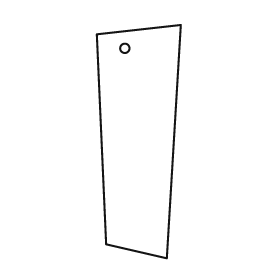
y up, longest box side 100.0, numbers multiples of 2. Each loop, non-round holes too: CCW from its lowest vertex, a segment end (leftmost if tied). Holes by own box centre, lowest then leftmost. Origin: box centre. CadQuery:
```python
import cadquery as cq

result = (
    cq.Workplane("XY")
    .moveTo(12.0, -50.0)
    .lineTo(18.0, 50.0)
    .lineTo(-18.0, 46.0)
    .lineTo(-14.0, -44.0)
    .close()
    .moveTo(-6.0, 40.0)
    .circle(2.0)
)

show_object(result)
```